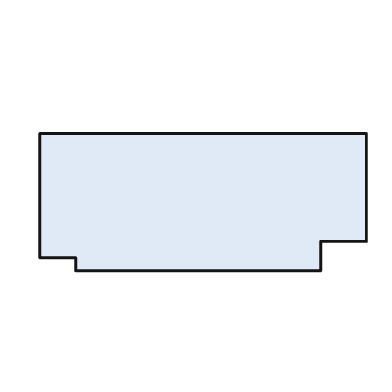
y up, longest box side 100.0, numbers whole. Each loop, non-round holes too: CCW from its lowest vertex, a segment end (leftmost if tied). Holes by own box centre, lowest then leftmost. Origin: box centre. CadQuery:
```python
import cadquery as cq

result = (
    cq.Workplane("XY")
    .moveTo(-39.0, -21.0)
    .lineTo(36.0, -21.0)
    .lineTo(36.0, -12.0)
    .lineTo(50.0, -12.0)
    .lineTo(50.0, 21.0)
    .lineTo(-50.0, 21.0)
    .lineTo(-50.0, -17.0)
    .lineTo(-39.0, -17.0)
    .close()
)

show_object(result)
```